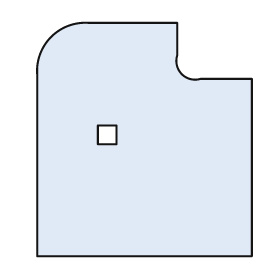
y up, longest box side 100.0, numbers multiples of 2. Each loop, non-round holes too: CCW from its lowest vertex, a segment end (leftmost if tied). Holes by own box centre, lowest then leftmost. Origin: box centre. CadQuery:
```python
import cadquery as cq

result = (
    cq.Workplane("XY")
    .moveTo(-46.0, -50.0)
    .lineTo(46.0, -50.0)
    .lineTo(46.0, 26.0)
    .lineTo(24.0, 26.0)
    .threePointArc((16.0, 28.0), (14.0, 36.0))
    .lineTo(14.0, 50.0)
    .lineTo(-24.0, 50.0)
    .threePointArc((-40.0, 44.0), (-46.0, 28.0))
    .close()
    .moveTo(-20.0, -2.0)
    .lineTo(-12.0, -2.0)
    .lineTo(-12.0, 6.0)
    .lineTo(-20.0, 6.0)
    .close()
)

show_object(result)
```